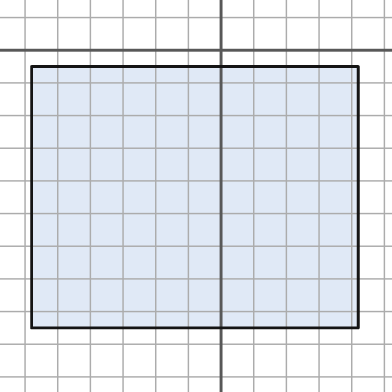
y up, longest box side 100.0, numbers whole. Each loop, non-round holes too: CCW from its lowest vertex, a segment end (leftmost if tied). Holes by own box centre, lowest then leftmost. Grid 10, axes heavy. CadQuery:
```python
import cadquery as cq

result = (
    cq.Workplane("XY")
    .moveTo(-58.0, -85.0)
    .lineTo(42.0, -85.0)
    .lineTo(42.0, -5.0)
    .lineTo(-58.0, -5.0)
    .close()
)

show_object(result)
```